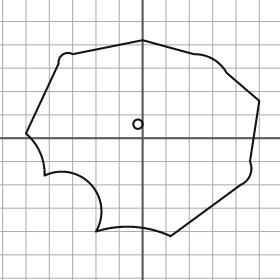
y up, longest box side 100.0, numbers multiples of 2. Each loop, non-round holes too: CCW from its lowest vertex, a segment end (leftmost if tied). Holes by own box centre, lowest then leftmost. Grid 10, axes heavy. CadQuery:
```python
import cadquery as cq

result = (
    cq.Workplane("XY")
    .moveTo(12.0, -42.0)
    .lineTo(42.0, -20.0)
    .threePointArc((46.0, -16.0), (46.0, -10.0))
    .lineTo(50.0, 16.0)
    .lineTo(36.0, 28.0)
    .threePointArc((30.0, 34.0), (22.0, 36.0))
    .lineTo(0.0, 42.0)
    .lineTo(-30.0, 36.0)
    .threePointArc((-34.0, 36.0), (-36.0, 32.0))
    .lineTo(-50.0, 2.0)
    .threePointArc((-44.0, -6.0), (-42.0, -16.0))
    .threePointArc((-22.0, -20.0), (-20.0, -40.0))
    .threePointArc((-4.0, -38.0), (12.0, -42.0))
    .close()
    .moveTo(-2.0, 6.0)
    .circle(2.0)
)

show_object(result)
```